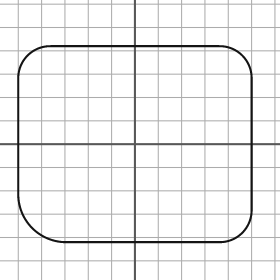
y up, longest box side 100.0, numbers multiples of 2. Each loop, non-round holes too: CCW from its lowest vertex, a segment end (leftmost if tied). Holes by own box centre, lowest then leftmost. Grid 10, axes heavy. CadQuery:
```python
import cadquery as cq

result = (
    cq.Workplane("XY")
    .moveTo(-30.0, -42.0)
    .lineTo(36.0, -42.0)
    .threePointArc((46.0, -38.0), (50.0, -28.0))
    .lineTo(50.0, 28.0)
    .threePointArc((46.0, 38.0), (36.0, 42.0))
    .lineTo(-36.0, 42.0)
    .threePointArc((-46.0, 38.0), (-50.0, 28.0))
    .lineTo(-50.0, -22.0)
    .threePointArc((-44.0, -36.0), (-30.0, -42.0))
    .close()
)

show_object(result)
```